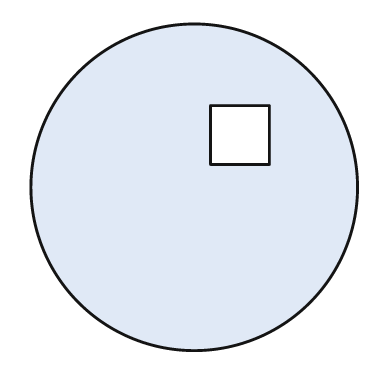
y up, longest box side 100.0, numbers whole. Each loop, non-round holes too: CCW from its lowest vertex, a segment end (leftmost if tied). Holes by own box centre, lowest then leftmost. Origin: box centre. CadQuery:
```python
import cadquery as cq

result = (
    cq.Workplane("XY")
    .moveTo(0.0, 0.0)
    .circle(50.0)
    .moveTo(5.0, 7.0)
    .lineTo(23.0, 7.0)
    .lineTo(23.0, 25.0)
    .lineTo(5.0, 25.0)
    .close()
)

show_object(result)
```